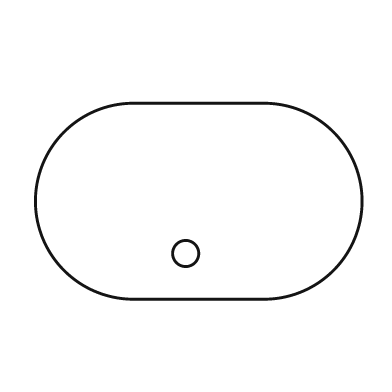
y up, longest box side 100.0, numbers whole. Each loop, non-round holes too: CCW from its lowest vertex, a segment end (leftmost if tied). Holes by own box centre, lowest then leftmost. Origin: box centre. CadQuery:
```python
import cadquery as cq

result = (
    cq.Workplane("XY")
    .moveTo(-20.0, -30.0)
    .lineTo(20.0, -30.0)
    .threePointArc((50.0, 0.0), (20.0, 30.0))
    .lineTo(-20.0, 30.0)
    .threePointArc((-50.0, 0.0), (-20.0, -30.0))
    .close()
    .moveTo(-4.0, -16.0)
    .circle(4.0)
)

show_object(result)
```